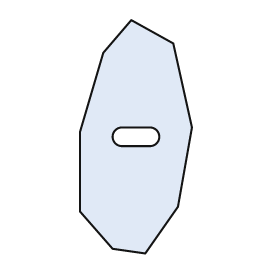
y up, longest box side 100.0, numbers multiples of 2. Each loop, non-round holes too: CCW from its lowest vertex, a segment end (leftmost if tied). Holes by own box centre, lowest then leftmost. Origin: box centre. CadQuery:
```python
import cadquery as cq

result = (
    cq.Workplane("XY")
    .moveTo(4.0, -50.0)
    .lineTo(18.0, -30.0)
    .lineTo(24.0, 4.0)
    .lineTo(16.0, 40.0)
    .lineTo(-2.0, 50.0)
    .lineTo(-14.0, 36.0)
    .lineTo(-24.0, 2.0)
    .lineTo(-24.0, -32.0)
    .lineTo(-10.0, -48.0)
    .close()
    .moveTo(-6.0, -4.0)
    .lineTo(6.0, -4.0)
    .threePointArc((10.0, 0.0), (6.0, 4.0))
    .lineTo(-6.0, 4.0)
    .threePointArc((-10.0, 0.0), (-6.0, -4.0))
    .close()
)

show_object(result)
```